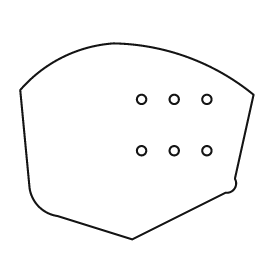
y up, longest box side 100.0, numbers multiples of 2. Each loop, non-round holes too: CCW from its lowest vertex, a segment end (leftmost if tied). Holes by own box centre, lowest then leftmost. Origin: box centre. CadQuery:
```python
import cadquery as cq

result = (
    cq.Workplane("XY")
    .moveTo(-2.0, -42.0)
    .lineTo(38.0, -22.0)
    .threePointArc((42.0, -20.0), (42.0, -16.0))
    .lineTo(50.0, 20.0)
    .threePointArc((22.0, 36.0), (-10.0, 42.0))
    .threePointArc((-32.0, 36.0), (-50.0, 22.0))
    .lineTo(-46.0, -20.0)
    .threePointArc((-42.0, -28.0), (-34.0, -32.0))
    .close()
    .moveTo(2.0, -4.0)
    .circle(2.0)
    .moveTo(16.0, -4.0)
    .circle(2.0)
    .moveTo(30.0, -4.0)
    .circle(2.0)
    .moveTo(2.0, 18.0)
    .circle(2.0)
    .moveTo(16.0, 18.0)
    .circle(2.0)
    .moveTo(30.0, 18.0)
    .circle(2.0)
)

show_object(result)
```